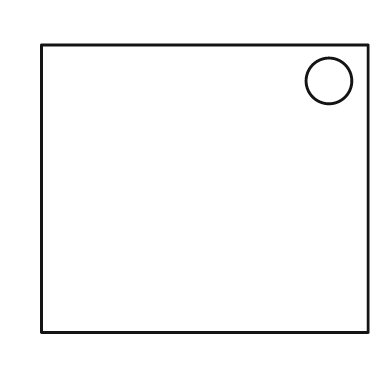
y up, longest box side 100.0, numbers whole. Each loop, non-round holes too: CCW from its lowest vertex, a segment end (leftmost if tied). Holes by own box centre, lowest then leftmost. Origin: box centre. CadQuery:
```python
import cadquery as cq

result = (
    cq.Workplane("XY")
    .moveTo(-50.0, -44.0)
    .lineTo(50.0, -44.0)
    .lineTo(50.0, 44.0)
    .lineTo(-50.0, 44.0)
    .close()
    .moveTo(38.0, 33.0)
    .circle(7.0)
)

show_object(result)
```